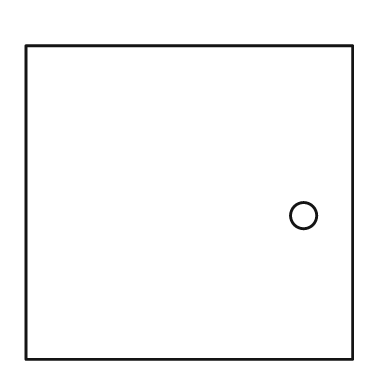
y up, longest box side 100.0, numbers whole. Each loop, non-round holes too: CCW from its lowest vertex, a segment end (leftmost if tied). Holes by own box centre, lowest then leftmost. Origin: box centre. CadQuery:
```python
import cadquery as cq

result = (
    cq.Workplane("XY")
    .moveTo(-50.0, -48.0)
    .lineTo(50.0, -48.0)
    .lineTo(50.0, 48.0)
    .lineTo(-50.0, 48.0)
    .close()
    .moveTo(35.0, -4.0)
    .circle(4.0)
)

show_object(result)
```